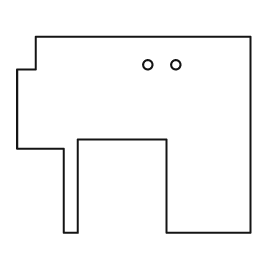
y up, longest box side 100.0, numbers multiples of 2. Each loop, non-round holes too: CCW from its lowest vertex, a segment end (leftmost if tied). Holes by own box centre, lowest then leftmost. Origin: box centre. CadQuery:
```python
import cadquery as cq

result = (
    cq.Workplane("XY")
    .moveTo(-30.0, -42.0)
    .lineTo(-24.0, -42.0)
    .lineTo(-24.0, -2.0)
    .lineTo(14.0, -2.0)
    .lineTo(14.0, -42.0)
    .lineTo(50.0, -42.0)
    .lineTo(50.0, 42.0)
    .lineTo(-42.0, 42.0)
    .lineTo(-42.0, 28.0)
    .lineTo(-50.0, 28.0)
    .lineTo(-50.0, -6.0)
    .lineTo(-30.0, -6.0)
    .close()
    .moveTo(6.0, 30.0)
    .circle(2.0)
    .moveTo(18.0, 30.0)
    .circle(2.0)
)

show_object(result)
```